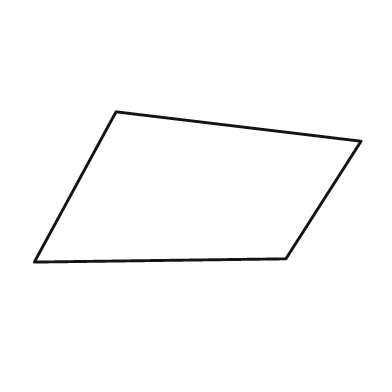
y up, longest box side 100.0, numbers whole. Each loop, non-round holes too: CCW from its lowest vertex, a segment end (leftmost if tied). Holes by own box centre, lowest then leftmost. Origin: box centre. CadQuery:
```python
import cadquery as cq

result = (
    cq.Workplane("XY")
    .moveTo(-50.0, -23.0)
    .lineTo(27.0, -22.0)
    .lineTo(50.0, 14.0)
    .lineTo(-25.0, 23.0)
    .close()
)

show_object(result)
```